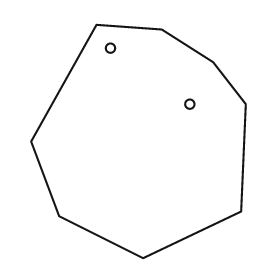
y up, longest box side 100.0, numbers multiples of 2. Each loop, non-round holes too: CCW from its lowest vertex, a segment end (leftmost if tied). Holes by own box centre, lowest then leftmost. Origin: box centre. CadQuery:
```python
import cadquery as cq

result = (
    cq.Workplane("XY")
    .moveTo(2.0, -50.0)
    .lineTo(44.0, -30.0)
    .lineTo(46.0, 16.0)
    .lineTo(32.0, 34.0)
    .lineTo(10.0, 48.0)
    .lineTo(-18.0, 50.0)
    .lineTo(-46.0, 0.0)
    .lineTo(-34.0, -32.0)
    .close()
    .moveTo(22.0, 16.0)
    .circle(2.0)
    .moveTo(-12.0, 40.0)
    .circle(2.0)
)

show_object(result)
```